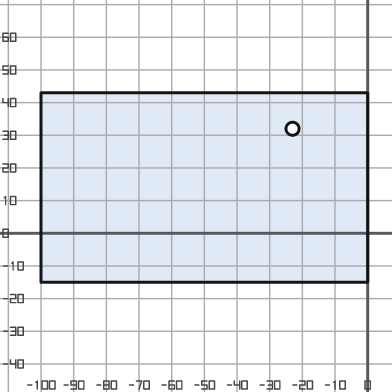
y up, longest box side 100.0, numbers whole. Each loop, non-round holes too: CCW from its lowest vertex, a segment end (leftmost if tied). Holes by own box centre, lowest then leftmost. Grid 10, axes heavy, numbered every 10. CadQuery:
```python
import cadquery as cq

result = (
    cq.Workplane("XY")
    .moveTo(-100.0, -15.0)
    .lineTo(0.0, -15.0)
    .lineTo(0.0, 43.0)
    .lineTo(-100.0, 43.0)
    .close()
    .moveTo(-23.0, 32.0)
    .circle(2.0)
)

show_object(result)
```